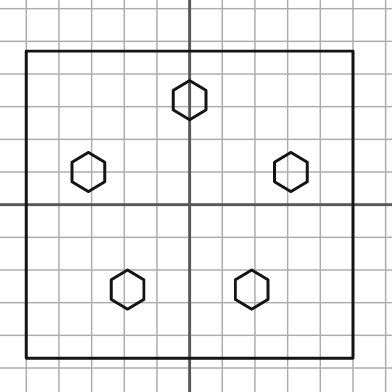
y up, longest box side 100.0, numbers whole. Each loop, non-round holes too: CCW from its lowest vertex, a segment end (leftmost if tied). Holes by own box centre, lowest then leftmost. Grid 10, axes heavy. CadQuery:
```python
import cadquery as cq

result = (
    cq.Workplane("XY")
    .moveTo(-50.0, -47.0)
    .lineTo(50.0, -47.0)
    .lineTo(50.0, 47.0)
    .lineTo(-50.0, 47.0)
    .close()
    .moveTo(-19.0, -32.0)
    .lineTo(-14.0, -29.0)
    .lineTo(-14.0, -23.0)
    .lineTo(-19.0, -20.0)
    .lineTo(-24.0, -23.0)
    .lineTo(-24.0, -29.0)
    .close()
    .moveTo(19.0, -32.0)
    .lineTo(24.0, -29.0)
    .lineTo(24.0, -23.0)
    .lineTo(19.0, -20.0)
    .lineTo(14.0, -23.0)
    .lineTo(14.0, -29.0)
    .close()
    .moveTo(-31.0, 4.0)
    .lineTo(-26.0, 7.0)
    .lineTo(-26.0, 13.0)
    .lineTo(-31.0, 16.0)
    .lineTo(-36.0, 13.0)
    .lineTo(-36.0, 7.0)
    .close()
    .moveTo(31.0, 4.0)
    .lineTo(36.0, 7.0)
    .lineTo(36.0, 13.0)
    .lineTo(31.0, 16.0)
    .lineTo(26.0, 13.0)
    .lineTo(26.0, 7.0)
    .close()
    .moveTo(0.0, 26.0)
    .lineTo(5.0, 29.0)
    .lineTo(5.0, 35.0)
    .lineTo(0.0, 38.0)
    .lineTo(-5.0, 35.0)
    .lineTo(-5.0, 29.0)
    .close()
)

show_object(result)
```